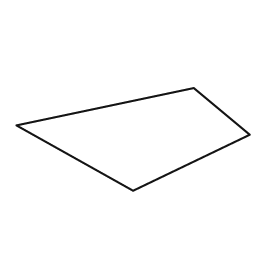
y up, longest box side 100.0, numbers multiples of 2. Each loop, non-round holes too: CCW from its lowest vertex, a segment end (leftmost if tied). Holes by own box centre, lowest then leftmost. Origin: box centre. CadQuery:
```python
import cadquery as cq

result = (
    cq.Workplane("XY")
    .moveTo(0.0, -22.0)
    .lineTo(50.0, 2.0)
    .lineTo(26.0, 22.0)
    .lineTo(-50.0, 6.0)
    .close()
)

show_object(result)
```